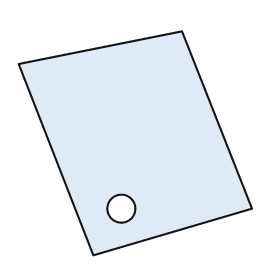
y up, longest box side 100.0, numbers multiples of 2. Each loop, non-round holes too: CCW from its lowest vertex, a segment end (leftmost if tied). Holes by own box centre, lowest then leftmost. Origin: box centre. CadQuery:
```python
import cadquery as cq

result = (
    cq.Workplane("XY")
    .moveTo(-18.0, -48.0)
    .lineTo(50.0, -28.0)
    .lineTo(20.0, 48.0)
    .lineTo(-50.0, 34.0)
    .close()
    .moveTo(-6.0, -28.0)
    .circle(6.0)
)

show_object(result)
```